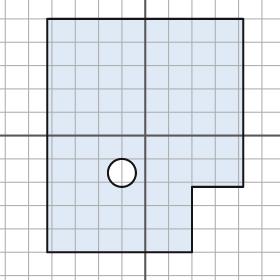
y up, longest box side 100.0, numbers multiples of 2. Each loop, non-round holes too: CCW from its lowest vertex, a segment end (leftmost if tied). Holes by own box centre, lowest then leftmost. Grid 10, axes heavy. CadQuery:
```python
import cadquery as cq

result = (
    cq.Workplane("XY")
    .moveTo(-42.0, -50.0)
    .lineTo(20.0, -50.0)
    .lineTo(20.0, -22.0)
    .lineTo(42.0, -22.0)
    .lineTo(42.0, 50.0)
    .lineTo(-42.0, 50.0)
    .close()
    .moveTo(-10.0, -16.0)
    .circle(6.0)
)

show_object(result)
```